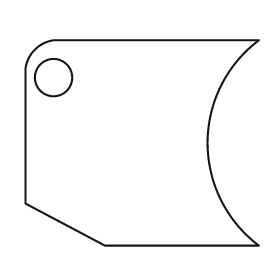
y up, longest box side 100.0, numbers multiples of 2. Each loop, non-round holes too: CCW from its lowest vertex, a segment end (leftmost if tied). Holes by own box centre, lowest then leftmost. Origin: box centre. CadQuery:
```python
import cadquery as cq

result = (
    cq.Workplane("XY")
    .moveTo(-16.0, -44.0)
    .lineTo(50.0, -44.0)
    .threePointArc((28.0, 0.0), (50.0, 44.0))
    .lineTo(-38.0, 44.0)
    .threePointArc((-46.0, 40.0), (-50.0, 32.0))
    .lineTo(-50.0, -26.0)
    .close()
    .moveTo(-38.0, 28.0)
    .circle(8.0)
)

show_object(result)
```